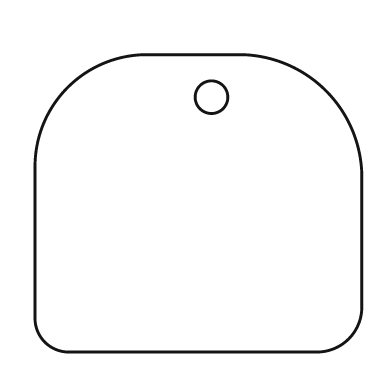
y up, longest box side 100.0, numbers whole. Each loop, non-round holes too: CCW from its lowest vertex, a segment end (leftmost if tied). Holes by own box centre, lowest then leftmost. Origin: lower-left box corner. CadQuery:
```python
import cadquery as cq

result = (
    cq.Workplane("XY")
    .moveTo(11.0, 0.0)
    .lineTo(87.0, 0.0)
    .threePointArc((96.0, 4.0), (100.0, 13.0))
    .lineTo(100.0, 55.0)
    .threePointArc((89.0, 80.0), (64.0, 91.0))
    .lineTo(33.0, 91.0)
    .threePointArc((10.0, 81.0), (0.0, 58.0))
    .lineTo(0.0, 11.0)
    .threePointArc((3.0, 3.0), (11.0, 0.0))
    .close()
    .moveTo(54.0, 78.0)
    .circle(5.0)
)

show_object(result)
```